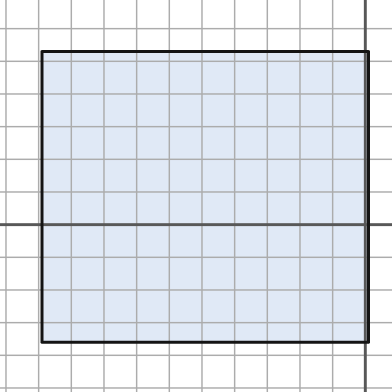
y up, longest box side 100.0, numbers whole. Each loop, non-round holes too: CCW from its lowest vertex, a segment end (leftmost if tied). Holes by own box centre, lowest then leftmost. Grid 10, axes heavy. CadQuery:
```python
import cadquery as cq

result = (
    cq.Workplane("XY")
    .moveTo(-99.0, -36.0)
    .lineTo(1.0, -36.0)
    .lineTo(1.0, 53.0)
    .lineTo(-99.0, 53.0)
    .close()
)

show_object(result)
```